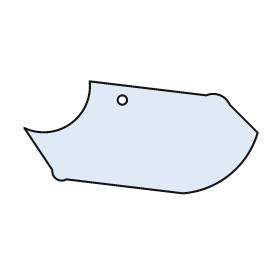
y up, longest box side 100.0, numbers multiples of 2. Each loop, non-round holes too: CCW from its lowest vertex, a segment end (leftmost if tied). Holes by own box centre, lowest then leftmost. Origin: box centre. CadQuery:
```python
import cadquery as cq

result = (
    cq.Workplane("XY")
    .moveTo(18.0, -24.0)
    .threePointArc((38.0, -16.0), (50.0, 2.0))
    .lineTo(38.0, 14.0)
    .threePointArc((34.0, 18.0), (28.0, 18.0))
    .lineTo(-22.0, 24.0)
    .threePointArc((-30.0, 6.0), (-50.0, 4.0))
    .lineTo(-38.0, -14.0)
    .threePointArc((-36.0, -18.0), (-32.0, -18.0))
    .close()
    .moveTo(-8.0, 16.0)
    .circle(2.0)
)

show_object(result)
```